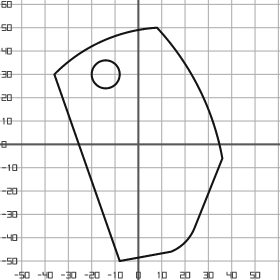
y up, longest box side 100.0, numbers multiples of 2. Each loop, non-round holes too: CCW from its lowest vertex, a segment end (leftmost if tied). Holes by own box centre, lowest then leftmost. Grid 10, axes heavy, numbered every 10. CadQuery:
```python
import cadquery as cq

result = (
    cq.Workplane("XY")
    .moveTo(-8.0, -50.0)
    .lineTo(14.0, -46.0)
    .threePointArc((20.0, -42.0), (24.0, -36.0))
    .lineTo(36.0, -6.0)
    .threePointArc((26.0, 24.0), (8.0, 50.0))
    .threePointArc((-16.0, 44.0), (-36.0, 30.0))
    .close()
    .moveTo(-14.0, 30.0)
    .circle(6.0)
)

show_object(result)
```